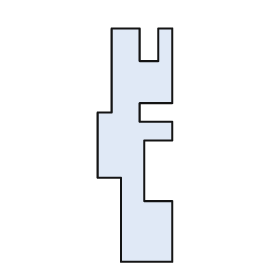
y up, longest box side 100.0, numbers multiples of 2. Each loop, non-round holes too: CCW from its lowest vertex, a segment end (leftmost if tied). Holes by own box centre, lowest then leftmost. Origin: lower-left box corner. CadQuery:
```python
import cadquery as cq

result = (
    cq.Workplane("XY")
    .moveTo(10.0, 0.0)
    .lineTo(32.0, 0.0)
    .lineTo(32.0, 26.0)
    .lineTo(20.0, 26.0)
    .lineTo(20.0, 52.0)
    .lineTo(32.0, 52.0)
    .lineTo(32.0, 60.0)
    .lineTo(18.0, 60.0)
    .lineTo(18.0, 68.0)
    .lineTo(32.0, 68.0)
    .lineTo(32.0, 100.0)
    .lineTo(26.0, 100.0)
    .lineTo(26.0, 86.0)
    .lineTo(18.0, 86.0)
    .lineTo(18.0, 100.0)
    .lineTo(6.0, 100.0)
    .lineTo(6.0, 64.0)
    .lineTo(0.0, 64.0)
    .lineTo(0.0, 36.0)
    .lineTo(10.0, 36.0)
    .close()
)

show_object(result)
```